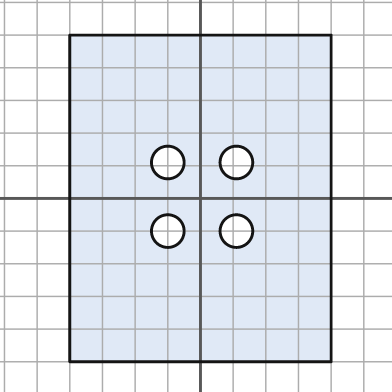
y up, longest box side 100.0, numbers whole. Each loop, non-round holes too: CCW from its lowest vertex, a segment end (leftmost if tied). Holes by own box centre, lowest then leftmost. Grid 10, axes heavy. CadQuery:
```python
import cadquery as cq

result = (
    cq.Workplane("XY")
    .moveTo(-40.0, -50.0)
    .lineTo(40.0, -50.0)
    .lineTo(40.0, 50.0)
    .lineTo(-40.0, 50.0)
    .close()
    .moveTo(-10.0, -10.0)
    .circle(5.0)
    .moveTo(11.0, -10.0)
    .circle(5.0)
    .moveTo(-10.0, 11.0)
    .circle(5.0)
    .moveTo(11.0, 11.0)
    .circle(5.0)
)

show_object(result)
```